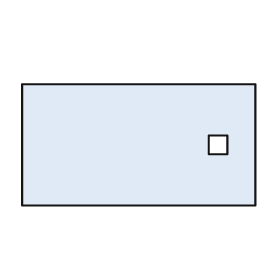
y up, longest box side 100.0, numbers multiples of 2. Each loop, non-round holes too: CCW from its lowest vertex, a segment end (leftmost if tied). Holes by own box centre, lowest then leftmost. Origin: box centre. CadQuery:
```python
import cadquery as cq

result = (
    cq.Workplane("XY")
    .moveTo(-50.0, -26.0)
    .lineTo(50.0, -26.0)
    .lineTo(50.0, 26.0)
    .lineTo(-50.0, 26.0)
    .close()
    .moveTo(30.0, -4.0)
    .lineTo(38.0, -4.0)
    .lineTo(38.0, 4.0)
    .lineTo(30.0, 4.0)
    .close()
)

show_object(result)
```